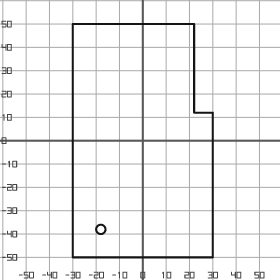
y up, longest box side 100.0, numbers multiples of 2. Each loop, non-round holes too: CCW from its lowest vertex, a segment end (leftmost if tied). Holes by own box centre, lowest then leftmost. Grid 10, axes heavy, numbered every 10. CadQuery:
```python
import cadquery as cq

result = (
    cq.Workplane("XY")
    .moveTo(-30.0, -50.0)
    .lineTo(30.0, -50.0)
    .lineTo(30.0, 12.0)
    .lineTo(22.0, 12.0)
    .lineTo(22.0, 50.0)
    .lineTo(-30.0, 50.0)
    .close()
    .moveTo(-18.0, -38.0)
    .circle(2.0)
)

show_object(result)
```